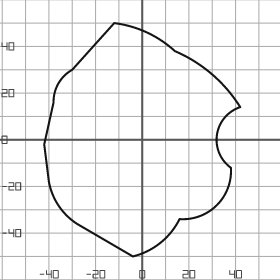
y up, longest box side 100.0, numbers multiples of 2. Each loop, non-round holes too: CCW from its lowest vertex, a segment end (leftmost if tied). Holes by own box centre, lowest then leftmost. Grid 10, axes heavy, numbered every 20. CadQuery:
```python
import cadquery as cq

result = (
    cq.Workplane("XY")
    .moveTo(-4.0, -50.0)
    .threePointArc((8.0, -44.0), (16.0, -34.0))
    .threePointArc((32.0, -28.0), (38.0, -12.0))
    .threePointArc((32.0, 2.0), (42.0, 14.0))
    .threePointArc((30.0, 28.0), (14.0, 38.0))
    .threePointArc((2.0, 46.0), (-12.0, 50.0))
    .lineTo(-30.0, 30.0)
    .threePointArc((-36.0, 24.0), (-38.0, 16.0))
    .lineTo(-42.0, -2.0)
    .lineTo(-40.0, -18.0)
    .threePointArc((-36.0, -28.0), (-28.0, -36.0))
    .close()
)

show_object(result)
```